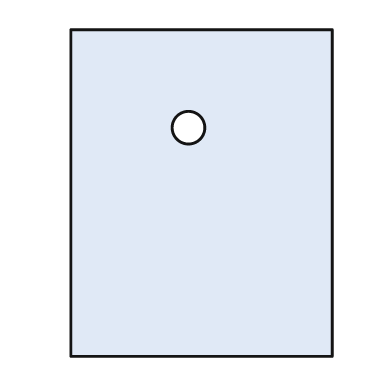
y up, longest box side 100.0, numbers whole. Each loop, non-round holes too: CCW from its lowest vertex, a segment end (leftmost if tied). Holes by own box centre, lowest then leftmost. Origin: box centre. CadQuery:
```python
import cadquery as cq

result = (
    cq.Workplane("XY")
    .moveTo(-40.0, -50.0)
    .lineTo(40.0, -50.0)
    .lineTo(40.0, 50.0)
    .lineTo(-40.0, 50.0)
    .close()
    .moveTo(-4.0, 20.0)
    .circle(5.0)
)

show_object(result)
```